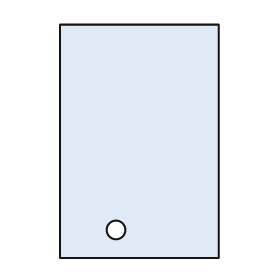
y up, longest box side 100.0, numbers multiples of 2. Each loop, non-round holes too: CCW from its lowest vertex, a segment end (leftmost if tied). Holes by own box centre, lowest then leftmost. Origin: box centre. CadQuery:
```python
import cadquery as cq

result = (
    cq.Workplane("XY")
    .moveTo(-34.0, -50.0)
    .lineTo(34.0, -50.0)
    .lineTo(34.0, 50.0)
    .lineTo(-34.0, 50.0)
    .close()
    .moveTo(-10.0, -38.0)
    .circle(4.0)
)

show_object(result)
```